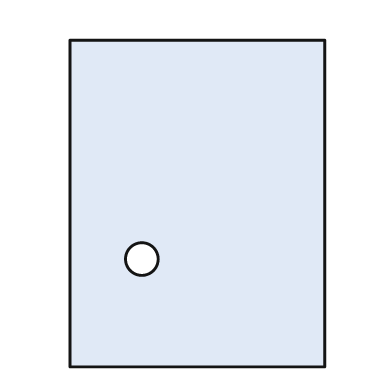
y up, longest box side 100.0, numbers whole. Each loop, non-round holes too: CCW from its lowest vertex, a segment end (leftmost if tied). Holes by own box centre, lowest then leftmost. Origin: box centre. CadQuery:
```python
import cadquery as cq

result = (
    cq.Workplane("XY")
    .moveTo(-39.0, -50.0)
    .lineTo(39.0, -50.0)
    .lineTo(39.0, 50.0)
    .lineTo(-39.0, 50.0)
    .close()
    .moveTo(-17.0, -17.0)
    .circle(5.0)
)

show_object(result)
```